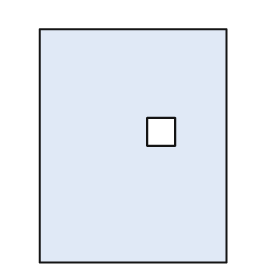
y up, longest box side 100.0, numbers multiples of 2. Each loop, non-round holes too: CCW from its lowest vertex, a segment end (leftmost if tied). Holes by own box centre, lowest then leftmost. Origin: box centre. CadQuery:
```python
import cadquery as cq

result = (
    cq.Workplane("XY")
    .moveTo(-40.0, -50.0)
    .lineTo(40.0, -50.0)
    .lineTo(40.0, 50.0)
    .lineTo(-40.0, 50.0)
    .close()
    .moveTo(6.0, 0.0)
    .lineTo(18.0, 0.0)
    .lineTo(18.0, 12.0)
    .lineTo(6.0, 12.0)
    .close()
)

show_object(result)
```